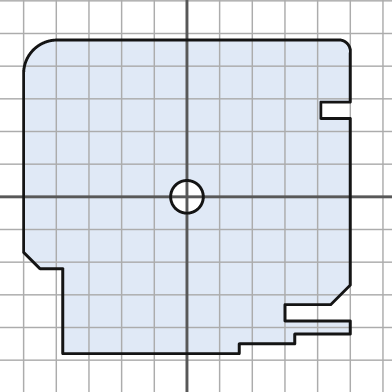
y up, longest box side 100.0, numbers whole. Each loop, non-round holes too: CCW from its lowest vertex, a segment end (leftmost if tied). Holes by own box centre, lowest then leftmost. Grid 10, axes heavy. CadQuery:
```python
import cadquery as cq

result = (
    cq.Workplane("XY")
    .moveTo(-38.0, -48.0)
    .lineTo(16.0, -48.0)
    .lineTo(16.0, -45.0)
    .lineTo(33.0, -45.0)
    .lineTo(33.0, -42.0)
    .lineTo(50.0, -42.0)
    .lineTo(50.0, -38.0)
    .lineTo(30.0, -38.0)
    .lineTo(30.0, -33.0)
    .lineTo(44.0, -33.0)
    .lineTo(50.0, -27.0)
    .lineTo(50.0, 24.0)
    .lineTo(41.0, 24.0)
    .lineTo(41.0, 29.0)
    .lineTo(50.0, 29.0)
    .lineTo(50.0, 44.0)
    .threePointArc((49.0, 47.0), (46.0, 48.0))
    .lineTo(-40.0, 48.0)
    .threePointArc((-47.0, 45.0), (-50.0, 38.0))
    .lineTo(-50.0, -17.0)
    .lineTo(-45.0, -22.0)
    .lineTo(-38.0, -22.0)
    .close()
    .moveTo(0.0, 0.0)
    .circle(5.0)
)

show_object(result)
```